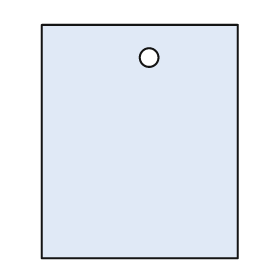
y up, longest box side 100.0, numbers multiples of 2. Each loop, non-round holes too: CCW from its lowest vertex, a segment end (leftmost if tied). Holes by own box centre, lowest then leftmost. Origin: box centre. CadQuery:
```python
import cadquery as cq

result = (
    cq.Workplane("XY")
    .moveTo(-42.0, -50.0)
    .lineTo(42.0, -50.0)
    .lineTo(42.0, 50.0)
    .lineTo(-42.0, 50.0)
    .close()
    .moveTo(4.0, 36.0)
    .circle(4.0)
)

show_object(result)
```